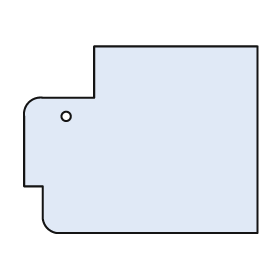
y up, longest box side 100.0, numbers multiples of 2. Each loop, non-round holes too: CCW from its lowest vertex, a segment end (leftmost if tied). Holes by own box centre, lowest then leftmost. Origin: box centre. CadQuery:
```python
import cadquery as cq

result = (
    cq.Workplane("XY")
    .moveTo(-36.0, -40.0)
    .lineTo(50.0, -40.0)
    .lineTo(50.0, 40.0)
    .lineTo(-20.0, 40.0)
    .lineTo(-20.0, 18.0)
    .lineTo(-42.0, 18.0)
    .threePointArc((-48.0, 16.0), (-50.0, 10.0))
    .lineTo(-50.0, -20.0)
    .lineTo(-42.0, -20.0)
    .lineTo(-42.0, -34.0)
    .threePointArc((-40.0, -38.0), (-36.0, -40.0))
    .close()
    .moveTo(-32.0, 10.0)
    .circle(2.0)
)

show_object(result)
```